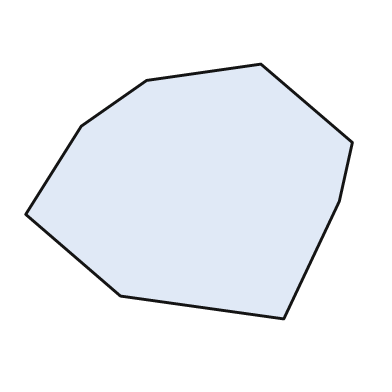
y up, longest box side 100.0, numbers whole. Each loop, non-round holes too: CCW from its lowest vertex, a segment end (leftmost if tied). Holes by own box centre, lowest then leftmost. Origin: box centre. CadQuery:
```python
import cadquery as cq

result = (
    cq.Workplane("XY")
    .moveTo(29.0, -39.0)
    .lineTo(46.0, -3.0)
    .lineTo(50.0, 15.0)
    .lineTo(22.0, 39.0)
    .lineTo(-13.0, 34.0)
    .lineTo(-33.0, 20.0)
    .lineTo(-50.0, -7.0)
    .lineTo(-21.0, -32.0)
    .close()
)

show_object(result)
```